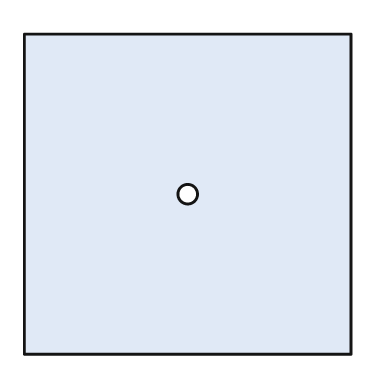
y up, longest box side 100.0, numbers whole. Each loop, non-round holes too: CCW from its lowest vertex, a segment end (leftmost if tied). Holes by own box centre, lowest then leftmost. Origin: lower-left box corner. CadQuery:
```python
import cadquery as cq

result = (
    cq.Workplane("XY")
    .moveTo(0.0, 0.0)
    .lineTo(100.0, 0.0)
    .lineTo(100.0, 98.0)
    .lineTo(0.0, 98.0)
    .close()
    .moveTo(50.0, 49.0)
    .circle(3.0)
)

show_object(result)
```